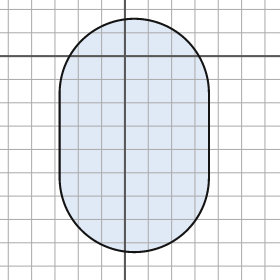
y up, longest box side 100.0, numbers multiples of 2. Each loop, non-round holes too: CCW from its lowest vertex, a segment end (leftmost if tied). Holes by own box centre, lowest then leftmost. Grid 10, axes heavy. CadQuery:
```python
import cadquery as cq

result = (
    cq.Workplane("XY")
    .moveTo(-28.0, -52.0)
    .threePointArc((4.0, -84.0), (36.0, -52.0))
    .lineTo(36.0, -16.0)
    .threePointArc((4.0, 16.0), (-28.0, -16.0))
    .close()
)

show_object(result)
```